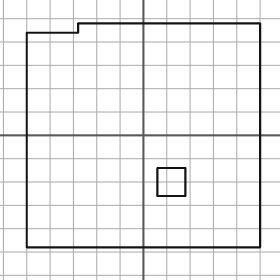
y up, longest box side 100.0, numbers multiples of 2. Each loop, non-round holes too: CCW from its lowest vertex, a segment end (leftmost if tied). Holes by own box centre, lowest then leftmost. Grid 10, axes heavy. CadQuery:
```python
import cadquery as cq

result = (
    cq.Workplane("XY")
    .moveTo(-50.0, -48.0)
    .lineTo(50.0, -48.0)
    .lineTo(50.0, 48.0)
    .lineTo(-28.0, 48.0)
    .lineTo(-28.0, 44.0)
    .lineTo(-50.0, 44.0)
    .close()
    .moveTo(6.0, -26.0)
    .lineTo(18.0, -26.0)
    .lineTo(18.0, -14.0)
    .lineTo(6.0, -14.0)
    .close()
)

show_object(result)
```